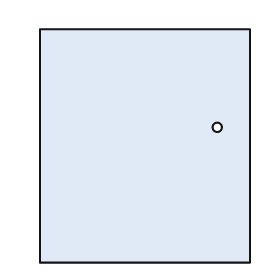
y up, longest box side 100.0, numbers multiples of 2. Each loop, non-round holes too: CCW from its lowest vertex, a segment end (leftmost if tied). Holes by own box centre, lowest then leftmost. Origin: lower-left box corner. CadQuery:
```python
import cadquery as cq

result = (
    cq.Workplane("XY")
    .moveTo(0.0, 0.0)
    .lineTo(90.0, 0.0)
    .lineTo(90.0, 100.0)
    .lineTo(0.0, 100.0)
    .close()
    .moveTo(76.0, 58.0)
    .circle(2.0)
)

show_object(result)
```